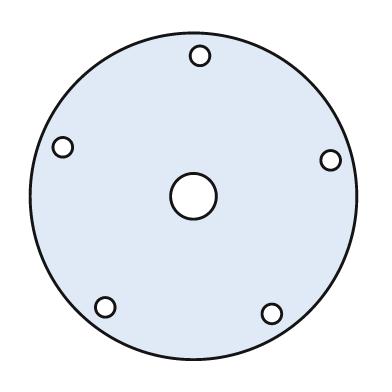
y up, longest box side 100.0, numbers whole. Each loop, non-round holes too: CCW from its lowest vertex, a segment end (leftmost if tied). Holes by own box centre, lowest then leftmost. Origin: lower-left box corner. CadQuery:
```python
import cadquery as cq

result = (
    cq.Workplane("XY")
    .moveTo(50.0, 50.0)
    .circle(50.0)
    .moveTo(74.0, 14.0)
    .circle(3.0)
    .moveTo(23.0, 16.0)
    .circle(3.0)
    .moveTo(50.0, 50.0)
    .circle(7.0)
    .moveTo(92.0, 61.0)
    .circle(3.0)
    .moveTo(10.0, 65.0)
    .circle(3.0)
    .moveTo(52.0, 93.0)
    .circle(3.0)
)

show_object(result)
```